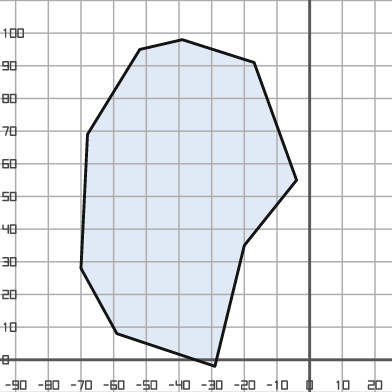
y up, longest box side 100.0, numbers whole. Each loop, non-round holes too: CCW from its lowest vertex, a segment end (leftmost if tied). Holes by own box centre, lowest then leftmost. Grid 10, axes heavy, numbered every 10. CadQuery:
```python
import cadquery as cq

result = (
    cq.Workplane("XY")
    .moveTo(-29.0, -2.0)
    .lineTo(-20.0, 35.0)
    .lineTo(-4.0, 55.0)
    .lineTo(-17.0, 91.0)
    .lineTo(-39.0, 98.0)
    .lineTo(-52.0, 95.0)
    .lineTo(-68.0, 69.0)
    .lineTo(-70.0, 28.0)
    .lineTo(-59.0, 8.0)
    .close()
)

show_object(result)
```